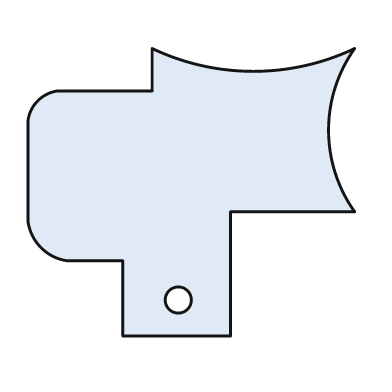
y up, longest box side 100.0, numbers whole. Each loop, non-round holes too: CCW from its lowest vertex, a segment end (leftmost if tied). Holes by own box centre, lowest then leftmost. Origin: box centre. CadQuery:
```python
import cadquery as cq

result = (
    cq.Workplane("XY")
    .moveTo(-21.0, -44.0)
    .lineTo(12.0, -44.0)
    .lineTo(12.0, -6.0)
    .lineTo(50.0, -6.0)
    .threePointArc((42.0, 19.0), (50.0, 44.0))
    .threePointArc((19.0, 37.0), (-12.0, 44.0))
    .lineTo(-12.0, 31.0)
    .lineTo(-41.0, 31.0)
    .threePointArc((-47.0, 28.0), (-50.0, 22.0))
    .lineTo(-50.0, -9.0)
    .threePointArc((-46.0, -17.0), (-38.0, -21.0))
    .lineTo(-21.0, -21.0)
    .close()
    .moveTo(-4.0, -33.0)
    .circle(4.0)
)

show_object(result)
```